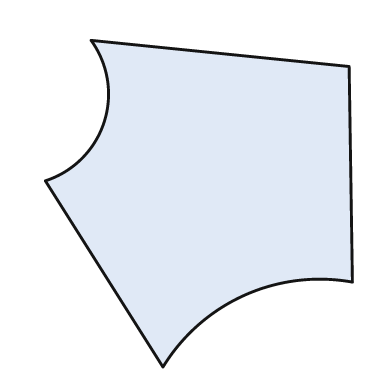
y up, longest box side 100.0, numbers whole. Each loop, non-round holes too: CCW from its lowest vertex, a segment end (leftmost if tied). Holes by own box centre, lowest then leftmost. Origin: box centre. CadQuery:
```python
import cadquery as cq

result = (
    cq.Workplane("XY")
    .moveTo(-11.0, -50.0)
    .threePointArc((14.0, -28.0), (47.0, -24.0))
    .lineTo(46.0, 42.0)
    .lineTo(-33.0, 50.0)
    .threePointArc((-29.0, 25.0), (-47.0, 7.0))
    .close()
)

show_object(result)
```